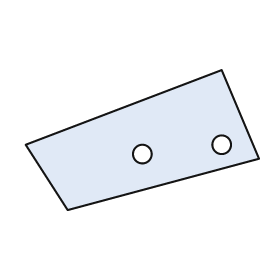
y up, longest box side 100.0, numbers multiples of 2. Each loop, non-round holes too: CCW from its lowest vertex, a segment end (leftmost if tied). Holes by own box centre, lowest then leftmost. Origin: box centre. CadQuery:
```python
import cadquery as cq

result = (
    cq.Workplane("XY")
    .moveTo(-32.0, -30.0)
    .lineTo(50.0, -8.0)
    .lineTo(34.0, 30.0)
    .lineTo(-50.0, -2.0)
    .close()
    .moveTo(0.0, -6.0)
    .circle(4.0)
    .moveTo(34.0, -2.0)
    .circle(4.0)
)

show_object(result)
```